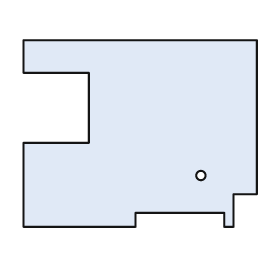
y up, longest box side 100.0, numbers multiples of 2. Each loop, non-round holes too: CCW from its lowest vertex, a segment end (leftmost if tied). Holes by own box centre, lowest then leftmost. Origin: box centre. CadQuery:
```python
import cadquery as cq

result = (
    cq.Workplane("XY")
    .moveTo(-50.0, -40.0)
    .lineTo(-2.0, -40.0)
    .lineTo(-2.0, -34.0)
    .lineTo(36.0, -34.0)
    .lineTo(36.0, -40.0)
    .lineTo(40.0, -40.0)
    .lineTo(40.0, -26.0)
    .lineTo(50.0, -26.0)
    .lineTo(50.0, 40.0)
    .lineTo(-50.0, 40.0)
    .lineTo(-50.0, 26.0)
    .lineTo(-22.0, 26.0)
    .lineTo(-22.0, -4.0)
    .lineTo(-50.0, -4.0)
    .close()
    .moveTo(26.0, -18.0)
    .circle(2.0)
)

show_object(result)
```